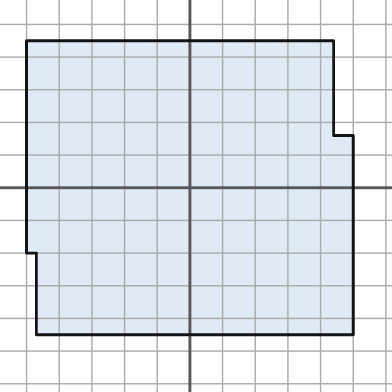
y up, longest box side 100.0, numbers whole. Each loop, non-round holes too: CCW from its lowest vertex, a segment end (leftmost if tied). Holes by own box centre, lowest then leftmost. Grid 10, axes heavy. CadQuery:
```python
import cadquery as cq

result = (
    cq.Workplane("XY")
    .moveTo(-47.0, -45.0)
    .lineTo(50.0, -45.0)
    .lineTo(50.0, 16.0)
    .lineTo(44.0, 16.0)
    .lineTo(44.0, 45.0)
    .lineTo(-50.0, 45.0)
    .lineTo(-50.0, -20.0)
    .lineTo(-47.0, -20.0)
    .close()
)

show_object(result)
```